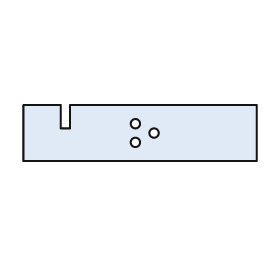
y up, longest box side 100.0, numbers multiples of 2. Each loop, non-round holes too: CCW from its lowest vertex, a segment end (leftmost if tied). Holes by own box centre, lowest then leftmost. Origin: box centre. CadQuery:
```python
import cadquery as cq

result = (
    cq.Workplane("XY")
    .moveTo(-50.0, -12.0)
    .lineTo(50.0, -12.0)
    .lineTo(50.0, 12.0)
    .lineTo(-30.0, 12.0)
    .lineTo(-30.0, 2.0)
    .lineTo(-34.0, 2.0)
    .lineTo(-34.0, 12.0)
    .lineTo(-50.0, 12.0)
    .close()
    .moveTo(-2.0, -4.0)
    .circle(2.0)
    .moveTo(6.0, 0.0)
    .circle(2.0)
    .moveTo(-2.0, 4.0)
    .circle(2.0)
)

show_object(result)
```